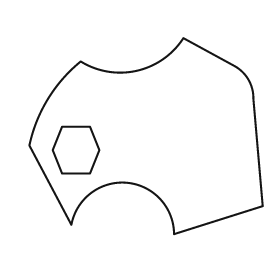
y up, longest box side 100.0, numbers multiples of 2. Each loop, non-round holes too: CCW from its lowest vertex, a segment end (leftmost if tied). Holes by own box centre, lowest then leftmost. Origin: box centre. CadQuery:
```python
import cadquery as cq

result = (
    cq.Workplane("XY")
    .moveTo(12.0, -42.0)
    .lineTo(50.0, -30.0)
    .lineTo(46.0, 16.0)
    .threePointArc((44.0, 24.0), (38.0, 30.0))
    .lineTo(16.0, 42.0)
    .threePointArc((-4.0, 28.0), (-28.0, 32.0))
    .threePointArc((-42.0, 16.0), (-50.0, -4.0))
    .lineTo(-32.0, -38.0)
    .threePointArc((-8.0, -20.0), (12.0, -42.0))
    .close()
    .moveTo(-36.0, -16.0)
    .lineTo(-24.0, -16.0)
    .lineTo(-20.0, -6.0)
    .lineTo(-24.0, 4.0)
    .lineTo(-36.0, 4.0)
    .lineTo(-40.0, -6.0)
    .close()
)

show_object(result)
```